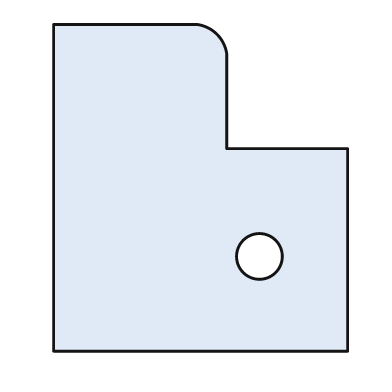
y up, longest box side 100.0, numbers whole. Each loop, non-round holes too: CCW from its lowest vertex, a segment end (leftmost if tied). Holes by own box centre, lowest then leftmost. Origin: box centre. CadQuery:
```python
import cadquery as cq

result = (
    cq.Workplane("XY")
    .moveTo(-45.0, -50.0)
    .lineTo(45.0, -50.0)
    .lineTo(45.0, 12.0)
    .lineTo(8.0, 12.0)
    .lineTo(8.0, 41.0)
    .threePointArc((5.0, 47.0), (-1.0, 50.0))
    .lineTo(-45.0, 50.0)
    .close()
    .moveTo(18.0, -21.0)
    .circle(7.0)
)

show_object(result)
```